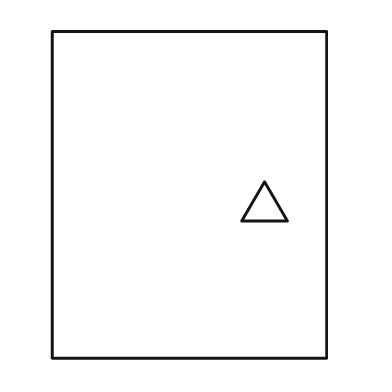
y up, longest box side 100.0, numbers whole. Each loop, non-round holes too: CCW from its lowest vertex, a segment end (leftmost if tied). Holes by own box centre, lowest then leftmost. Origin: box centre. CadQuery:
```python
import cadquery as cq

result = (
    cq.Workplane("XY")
    .moveTo(-42.0, -50.0)
    .lineTo(42.0, -50.0)
    .lineTo(42.0, 50.0)
    .lineTo(-42.0, 50.0)
    .close()
    .moveTo(16.0, -8.0)
    .lineTo(30.0, -8.0)
    .lineTo(23.0, 4.0)
    .close()
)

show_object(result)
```